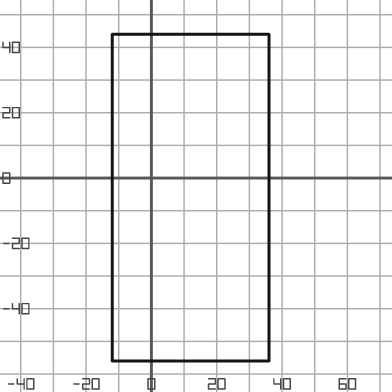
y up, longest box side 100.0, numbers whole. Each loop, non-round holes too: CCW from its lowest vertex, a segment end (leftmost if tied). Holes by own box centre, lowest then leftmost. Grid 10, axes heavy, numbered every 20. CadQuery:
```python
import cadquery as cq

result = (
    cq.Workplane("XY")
    .moveTo(-12.0, -56.0)
    .lineTo(36.0, -56.0)
    .lineTo(36.0, 44.0)
    .lineTo(-12.0, 44.0)
    .close()
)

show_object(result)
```